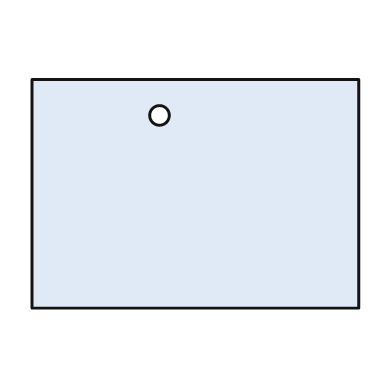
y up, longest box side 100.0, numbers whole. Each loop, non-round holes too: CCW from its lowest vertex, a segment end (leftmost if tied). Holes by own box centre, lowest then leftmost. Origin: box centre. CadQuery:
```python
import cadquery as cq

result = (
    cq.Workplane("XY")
    .moveTo(-50.0, -35.0)
    .lineTo(50.0, -35.0)
    .lineTo(50.0, 35.0)
    .lineTo(-50.0, 35.0)
    .close()
    .moveTo(-11.0, 24.0)
    .circle(3.0)
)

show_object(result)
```